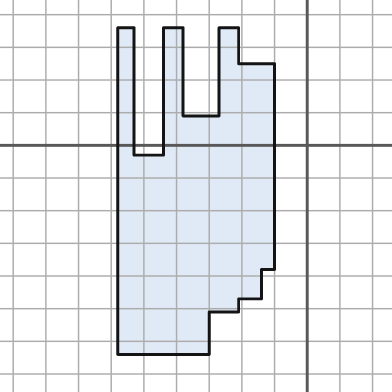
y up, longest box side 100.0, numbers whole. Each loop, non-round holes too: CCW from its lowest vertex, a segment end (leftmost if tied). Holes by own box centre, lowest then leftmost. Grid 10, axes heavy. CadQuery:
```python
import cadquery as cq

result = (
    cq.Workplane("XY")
    .moveTo(-58.0, -64.0)
    .lineTo(-30.0, -64.0)
    .lineTo(-30.0, -51.0)
    .lineTo(-21.0, -51.0)
    .lineTo(-21.0, -47.0)
    .lineTo(-14.0, -47.0)
    .lineTo(-14.0, -38.0)
    .lineTo(-10.0, -38.0)
    .lineTo(-10.0, 25.0)
    .lineTo(-21.0, 25.0)
    .lineTo(-21.0, 36.0)
    .lineTo(-27.0, 36.0)
    .lineTo(-27.0, 9.0)
    .lineTo(-38.0, 9.0)
    .lineTo(-38.0, 36.0)
    .lineTo(-44.0, 36.0)
    .lineTo(-44.0, -3.0)
    .lineTo(-53.0, -3.0)
    .lineTo(-53.0, 36.0)
    .lineTo(-58.0, 36.0)
    .close()
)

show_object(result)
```